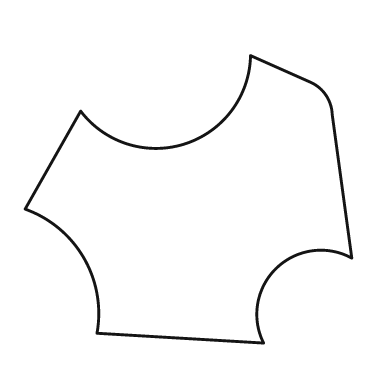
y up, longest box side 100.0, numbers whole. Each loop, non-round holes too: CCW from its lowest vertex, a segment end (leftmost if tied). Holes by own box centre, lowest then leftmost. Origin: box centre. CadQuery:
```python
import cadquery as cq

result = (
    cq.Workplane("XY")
    .moveTo(23.0, -44.0)
    .threePointArc((27.0, -21.0), (50.0, -18.0))
    .lineTo(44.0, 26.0)
    .threePointArc((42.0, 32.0), (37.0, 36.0))
    .lineTo(19.0, 44.0)
    .threePointArc((-1.0, 17.0), (-33.0, 27.0))
    .lineTo(-50.0, -3.0)
    .threePointArc((-32.0, -18.0), (-28.0, -41.0))
    .close()
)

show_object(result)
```